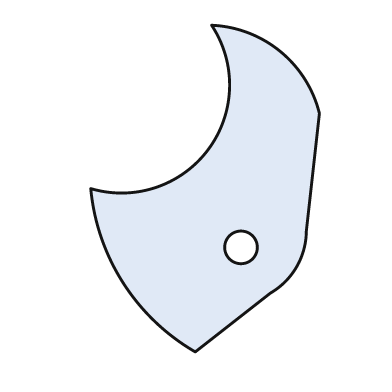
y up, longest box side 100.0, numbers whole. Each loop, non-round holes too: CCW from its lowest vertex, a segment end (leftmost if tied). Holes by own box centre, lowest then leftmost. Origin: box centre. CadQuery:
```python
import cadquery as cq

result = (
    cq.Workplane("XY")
    .moveTo(-3.0, -50.0)
    .lineTo(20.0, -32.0)
    .threePointArc((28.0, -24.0), (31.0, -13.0))
    .lineTo(35.0, 23.0)
    .threePointArc((23.0, 42.0), (2.0, 50.0))
    .threePointArc((1.0, 12.0), (-35.0, 0.0))
    .threePointArc((-25.0, -29.0), (-3.0, -50.0))
    .close()
    .moveTo(11.0, -18.0)
    .circle(5.0)
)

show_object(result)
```